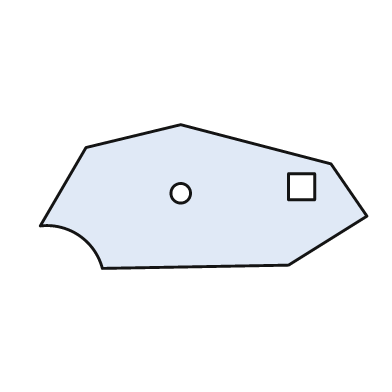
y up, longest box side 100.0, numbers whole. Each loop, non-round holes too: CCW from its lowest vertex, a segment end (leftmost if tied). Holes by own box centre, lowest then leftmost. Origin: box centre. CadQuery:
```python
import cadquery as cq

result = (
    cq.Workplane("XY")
    .moveTo(-31.0, -22.0)
    .lineTo(26.0, -21.0)
    .lineTo(50.0, -6.0)
    .lineTo(39.0, 10.0)
    .lineTo(-7.0, 22.0)
    .lineTo(-36.0, 15.0)
    .lineTo(-50.0, -9.0)
    .threePointArc((-38.0, -12.0), (-31.0, -22.0))
    .close()
    .moveTo(-7.0, 1.0)
    .circle(3.0)
    .moveTo(26.0, -1.0)
    .lineTo(34.0, -1.0)
    .lineTo(34.0, 7.0)
    .lineTo(26.0, 7.0)
    .close()
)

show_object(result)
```